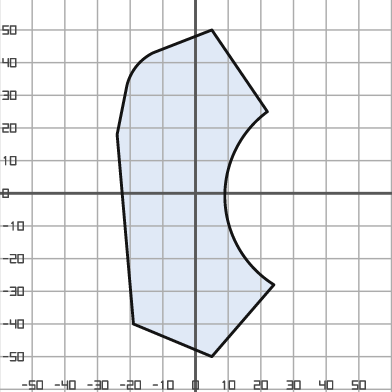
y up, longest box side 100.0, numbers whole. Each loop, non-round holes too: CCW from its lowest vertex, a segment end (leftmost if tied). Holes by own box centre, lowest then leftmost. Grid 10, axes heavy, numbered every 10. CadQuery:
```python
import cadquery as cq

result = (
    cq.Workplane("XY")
    .moveTo(5.0, -50.0)
    .lineTo(24.0, -28.0)
    .threePointArc((9.0, -2.0), (22.0, 25.0))
    .lineTo(5.0, 50.0)
    .lineTo(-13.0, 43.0)
    .threePointArc((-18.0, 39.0), (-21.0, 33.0))
    .lineTo(-24.0, 18.0)
    .lineTo(-19.0, -40.0)
    .close()
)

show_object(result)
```